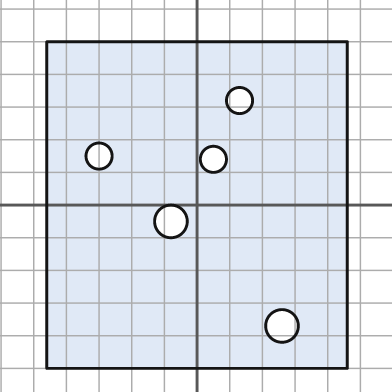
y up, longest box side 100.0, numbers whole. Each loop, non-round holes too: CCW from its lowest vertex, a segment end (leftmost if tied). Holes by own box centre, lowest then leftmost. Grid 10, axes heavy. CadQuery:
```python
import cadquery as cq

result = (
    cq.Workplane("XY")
    .moveTo(-46.0, -50.0)
    .lineTo(46.0, -50.0)
    .lineTo(46.0, 50.0)
    .lineTo(-46.0, 50.0)
    .close()
    .moveTo(26.0, -37.0)
    .circle(5.0)
    .moveTo(-8.0, -5.0)
    .circle(5.0)
    .moveTo(5.0, 14.0)
    .circle(4.0)
    .moveTo(-30.0, 15.0)
    .circle(4.0)
    .moveTo(13.0, 32.0)
    .circle(4.0)
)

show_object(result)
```